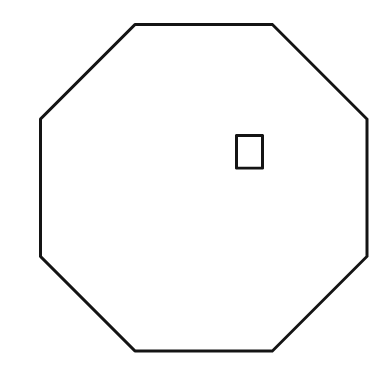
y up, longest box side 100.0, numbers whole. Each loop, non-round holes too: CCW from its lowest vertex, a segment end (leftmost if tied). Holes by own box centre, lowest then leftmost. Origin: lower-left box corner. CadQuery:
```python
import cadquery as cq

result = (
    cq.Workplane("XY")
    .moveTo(29.0, 0.0)
    .lineTo(71.0, 0.0)
    .lineTo(100.0, 29.0)
    .lineTo(100.0, 71.0)
    .lineTo(71.0, 100.0)
    .lineTo(29.0, 100.0)
    .lineTo(0.0, 71.0)
    .lineTo(0.0, 29.0)
    .close()
    .moveTo(60.0, 56.0)
    .lineTo(68.0, 56.0)
    .lineTo(68.0, 66.0)
    .lineTo(60.0, 66.0)
    .close()
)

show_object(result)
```